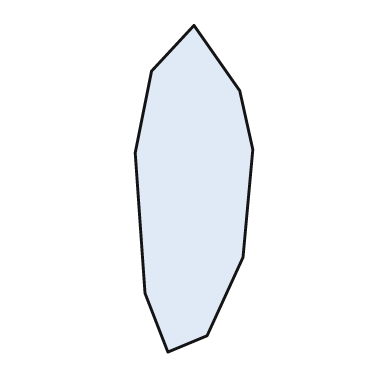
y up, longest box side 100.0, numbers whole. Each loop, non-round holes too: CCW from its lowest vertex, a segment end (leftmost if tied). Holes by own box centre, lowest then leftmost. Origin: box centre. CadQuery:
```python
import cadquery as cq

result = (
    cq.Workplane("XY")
    .moveTo(-8.0, -50.0)
    .lineTo(4.0, -45.0)
    .lineTo(15.0, -21.0)
    .lineTo(18.0, 12.0)
    .lineTo(14.0, 30.0)
    .lineTo(0.0, 50.0)
    .lineTo(-13.0, 36.0)
    .lineTo(-18.0, 11.0)
    .lineTo(-15.0, -32.0)
    .close()
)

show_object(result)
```